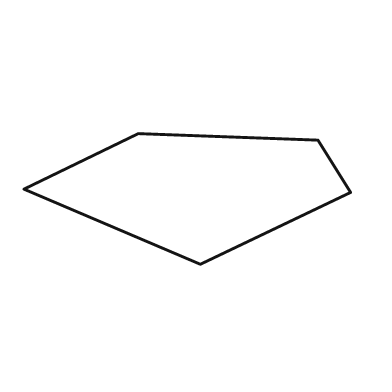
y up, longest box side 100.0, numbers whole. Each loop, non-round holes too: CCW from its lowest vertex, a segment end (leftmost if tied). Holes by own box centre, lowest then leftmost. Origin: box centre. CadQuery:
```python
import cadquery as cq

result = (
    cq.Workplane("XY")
    .moveTo(4.0, -20.0)
    .lineTo(50.0, 2.0)
    .lineTo(40.0, 18.0)
    .lineTo(-15.0, 20.0)
    .lineTo(-50.0, 3.0)
    .close()
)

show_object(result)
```